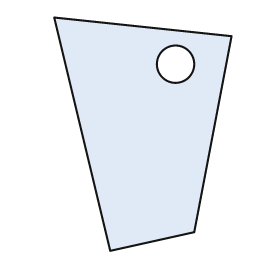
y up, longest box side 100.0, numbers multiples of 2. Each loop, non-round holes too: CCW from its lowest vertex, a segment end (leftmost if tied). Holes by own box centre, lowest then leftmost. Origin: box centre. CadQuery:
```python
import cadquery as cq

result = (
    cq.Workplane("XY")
    .moveTo(-14.0, -50.0)
    .lineTo(22.0, -42.0)
    .lineTo(38.0, 42.0)
    .lineTo(-38.0, 50.0)
    .close()
    .moveTo(14.0, 30.0)
    .circle(8.0)
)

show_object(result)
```